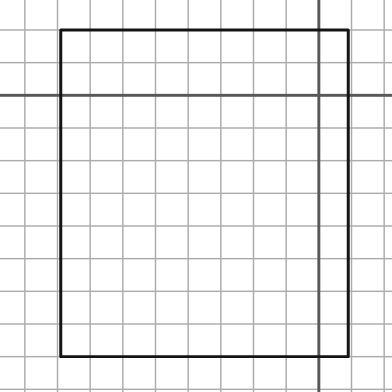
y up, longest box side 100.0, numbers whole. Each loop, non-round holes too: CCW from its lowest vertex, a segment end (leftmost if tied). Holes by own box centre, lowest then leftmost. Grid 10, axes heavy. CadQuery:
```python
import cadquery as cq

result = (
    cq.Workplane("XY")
    .moveTo(-79.0, -80.0)
    .lineTo(9.0, -80.0)
    .lineTo(9.0, 20.0)
    .lineTo(-79.0, 20.0)
    .close()
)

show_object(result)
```